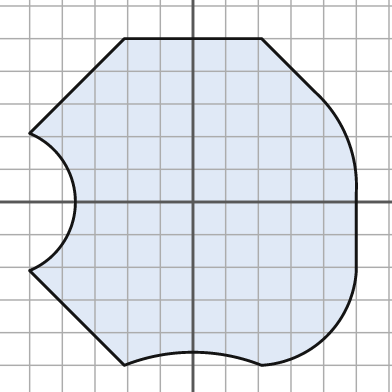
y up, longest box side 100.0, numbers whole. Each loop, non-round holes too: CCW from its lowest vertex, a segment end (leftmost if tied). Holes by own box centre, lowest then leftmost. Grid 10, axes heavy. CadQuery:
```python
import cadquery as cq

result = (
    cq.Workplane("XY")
    .moveTo(-21.0, -50.0)
    .threePointArc((0.0, -46.0), (21.0, -50.0))
    .threePointArc((41.0, -41.0), (50.0, -21.0))
    .lineTo(50.0, 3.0)
    .threePointArc((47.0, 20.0), (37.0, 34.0))
    .lineTo(21.0, 50.0)
    .lineTo(-21.0, 50.0)
    .lineTo(-50.0, 21.0)
    .threePointArc((-36.0, 0.0), (-50.0, -21.0))
    .close()
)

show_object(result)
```